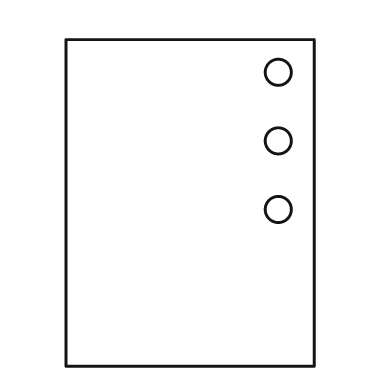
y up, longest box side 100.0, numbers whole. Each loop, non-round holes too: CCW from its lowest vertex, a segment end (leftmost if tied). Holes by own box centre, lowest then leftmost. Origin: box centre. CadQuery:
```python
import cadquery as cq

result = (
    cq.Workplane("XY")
    .moveTo(-38.0, -50.0)
    .lineTo(38.0, -50.0)
    .lineTo(38.0, 50.0)
    .lineTo(-38.0, 50.0)
    .close()
    .moveTo(27.0, -2.0)
    .circle(4.0)
    .moveTo(27.0, 19.0)
    .circle(4.0)
    .moveTo(27.0, 40.0)
    .circle(4.0)
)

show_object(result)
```